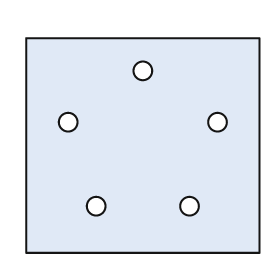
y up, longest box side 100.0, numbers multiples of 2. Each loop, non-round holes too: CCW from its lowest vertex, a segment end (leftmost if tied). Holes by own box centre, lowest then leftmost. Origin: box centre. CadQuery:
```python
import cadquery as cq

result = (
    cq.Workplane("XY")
    .moveTo(-50.0, -46.0)
    .lineTo(50.0, -46.0)
    .lineTo(50.0, 46.0)
    .lineTo(-50.0, 46.0)
    .close()
    .moveTo(-20.0, -26.0)
    .circle(4.0)
    .moveTo(20.0, -26.0)
    .circle(4.0)
    .moveTo(-32.0, 10.0)
    .circle(4.0)
    .moveTo(32.0, 10.0)
    .circle(4.0)
    .moveTo(0.0, 32.0)
    .circle(4.0)
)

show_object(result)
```